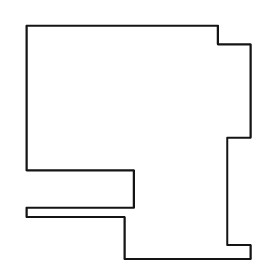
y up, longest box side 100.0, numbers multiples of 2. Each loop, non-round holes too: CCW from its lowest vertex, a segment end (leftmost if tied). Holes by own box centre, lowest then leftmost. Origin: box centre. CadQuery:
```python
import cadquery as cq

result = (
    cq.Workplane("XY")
    .moveTo(-6.0, -50.0)
    .lineTo(48.0, -50.0)
    .lineTo(48.0, -44.0)
    .lineTo(38.0, -44.0)
    .lineTo(38.0, 2.0)
    .lineTo(48.0, 2.0)
    .lineTo(48.0, 42.0)
    .lineTo(34.0, 42.0)
    .lineTo(34.0, 50.0)
    .lineTo(-48.0, 50.0)
    .lineTo(-48.0, -12.0)
    .lineTo(-2.0, -12.0)
    .lineTo(-2.0, -28.0)
    .lineTo(-48.0, -28.0)
    .lineTo(-48.0, -32.0)
    .lineTo(-6.0, -32.0)
    .close()
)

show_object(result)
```